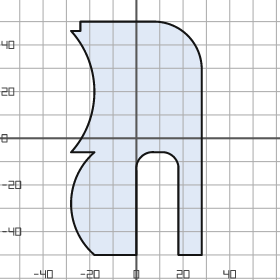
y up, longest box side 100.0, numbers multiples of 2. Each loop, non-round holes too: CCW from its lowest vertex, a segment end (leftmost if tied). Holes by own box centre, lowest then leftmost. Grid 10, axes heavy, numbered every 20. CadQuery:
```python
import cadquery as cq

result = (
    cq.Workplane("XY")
    .moveTo(-18.0, -50.0)
    .lineTo(0.0, -50.0)
    .lineTo(0.0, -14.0)
    .threePointArc((2.0, -8.0), (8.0, -6.0))
    .lineTo(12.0, -6.0)
    .threePointArc((16.0, -8.0), (18.0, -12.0))
    .lineTo(18.0, -50.0)
    .lineTo(28.0, -50.0)
    .lineTo(28.0, 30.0)
    .threePointArc((22.0, 44.0), (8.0, 50.0))
    .lineTo(-24.0, 50.0)
    .lineTo(-24.0, 46.0)
    .lineTo(-28.0, 46.0)
    .threePointArc((-18.0, 20.0), (-28.0, -6.0))
    .lineTo(-18.0, -6.0)
    .threePointArc((-28.0, -28.0), (-18.0, -50.0))
    .close()
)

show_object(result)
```